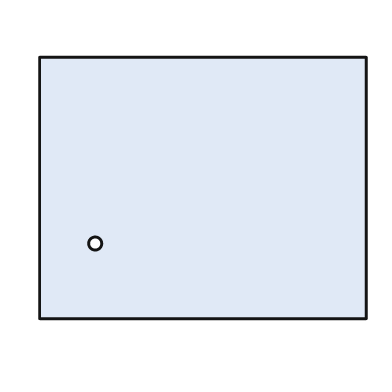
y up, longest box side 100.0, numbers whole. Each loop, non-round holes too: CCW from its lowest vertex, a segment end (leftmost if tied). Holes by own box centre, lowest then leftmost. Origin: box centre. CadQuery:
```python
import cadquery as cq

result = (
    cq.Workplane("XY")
    .moveTo(-50.0, -40.0)
    .lineTo(50.0, -40.0)
    .lineTo(50.0, 40.0)
    .lineTo(-50.0, 40.0)
    .close()
    .moveTo(-33.0, -17.0)
    .circle(2.0)
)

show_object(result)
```